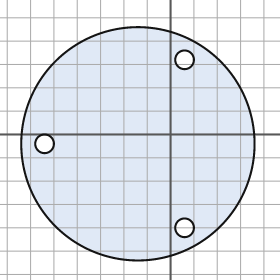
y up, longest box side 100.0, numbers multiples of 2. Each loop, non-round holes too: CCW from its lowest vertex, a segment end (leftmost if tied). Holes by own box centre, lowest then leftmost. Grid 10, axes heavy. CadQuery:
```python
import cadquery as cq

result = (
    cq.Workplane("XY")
    .moveTo(-14.0, -4.0)
    .circle(50.0)
    .moveTo(6.0, -40.0)
    .circle(4.0)
    .moveTo(-54.0, -4.0)
    .circle(4.0)
    .moveTo(6.0, 32.0)
    .circle(4.0)
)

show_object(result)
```